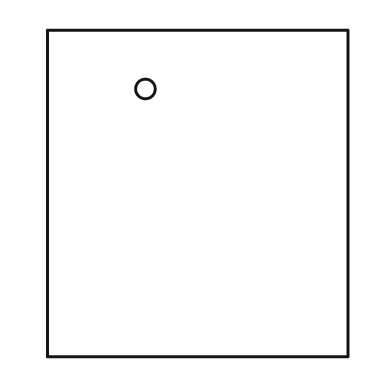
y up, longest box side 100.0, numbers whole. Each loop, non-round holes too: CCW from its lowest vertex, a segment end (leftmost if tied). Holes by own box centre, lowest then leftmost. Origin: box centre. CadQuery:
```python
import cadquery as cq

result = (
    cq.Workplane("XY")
    .moveTo(-46.0, -50.0)
    .lineTo(46.0, -50.0)
    .lineTo(46.0, 50.0)
    .lineTo(-46.0, 50.0)
    .close()
    .moveTo(-16.0, 32.0)
    .circle(3.0)
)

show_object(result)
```